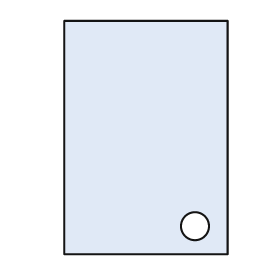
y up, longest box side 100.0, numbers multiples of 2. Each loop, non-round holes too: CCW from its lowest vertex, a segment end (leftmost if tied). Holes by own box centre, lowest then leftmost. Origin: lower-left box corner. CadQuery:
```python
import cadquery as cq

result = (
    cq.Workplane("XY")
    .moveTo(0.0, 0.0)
    .lineTo(70.0, 0.0)
    .lineTo(70.0, 100.0)
    .lineTo(0.0, 100.0)
    .close()
    .moveTo(56.0, 12.0)
    .circle(6.0)
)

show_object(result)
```